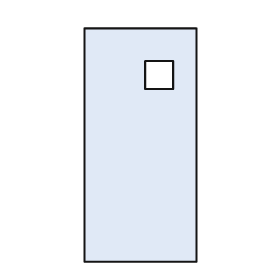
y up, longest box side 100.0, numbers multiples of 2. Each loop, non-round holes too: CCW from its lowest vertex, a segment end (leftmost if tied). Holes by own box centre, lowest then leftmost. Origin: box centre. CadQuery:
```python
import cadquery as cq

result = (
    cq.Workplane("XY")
    .moveTo(-24.0, -50.0)
    .lineTo(24.0, -50.0)
    .lineTo(24.0, 50.0)
    .lineTo(-24.0, 50.0)
    .close()
    .moveTo(2.0, 24.0)
    .lineTo(14.0, 24.0)
    .lineTo(14.0, 36.0)
    .lineTo(2.0, 36.0)
    .close()
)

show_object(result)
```